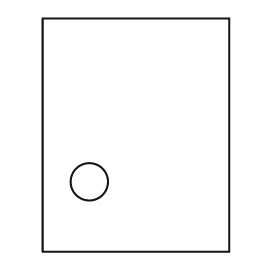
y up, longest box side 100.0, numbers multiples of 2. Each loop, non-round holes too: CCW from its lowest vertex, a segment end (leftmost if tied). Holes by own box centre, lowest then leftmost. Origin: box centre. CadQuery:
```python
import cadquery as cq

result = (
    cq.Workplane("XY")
    .moveTo(-40.0, -50.0)
    .lineTo(40.0, -50.0)
    .lineTo(40.0, 50.0)
    .lineTo(-40.0, 50.0)
    .close()
    .moveTo(-20.0, -20.0)
    .circle(8.0)
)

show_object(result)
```